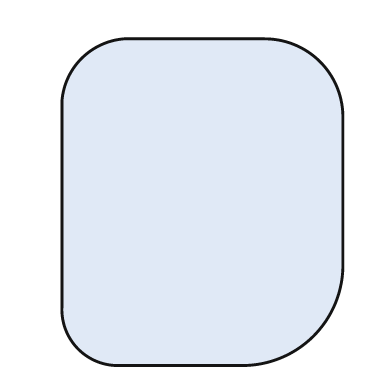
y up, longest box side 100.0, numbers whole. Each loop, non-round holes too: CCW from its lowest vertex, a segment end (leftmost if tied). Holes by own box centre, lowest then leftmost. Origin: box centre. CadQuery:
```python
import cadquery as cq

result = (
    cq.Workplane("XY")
    .moveTo(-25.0, -50.0)
    .lineTo(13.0, -50.0)
    .threePointArc((34.0, -41.0), (43.0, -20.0))
    .lineTo(43.0, 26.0)
    .threePointArc((36.0, 43.0), (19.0, 50.0))
    .lineTo(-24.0, 50.0)
    .threePointArc((-37.0, 44.0), (-43.0, 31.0))
    .lineTo(-43.0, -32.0)
    .threePointArc((-38.0, -45.0), (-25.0, -50.0))
    .close()
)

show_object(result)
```